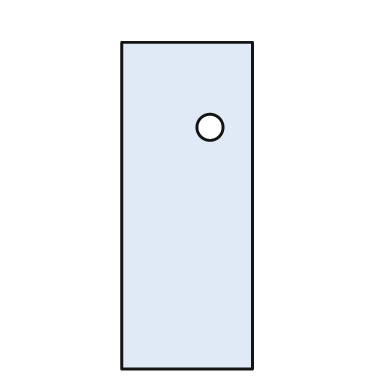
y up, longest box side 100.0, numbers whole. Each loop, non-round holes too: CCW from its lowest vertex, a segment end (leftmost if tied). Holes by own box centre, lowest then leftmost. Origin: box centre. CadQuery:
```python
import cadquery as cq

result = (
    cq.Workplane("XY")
    .moveTo(-20.0, -50.0)
    .lineTo(20.0, -50.0)
    .lineTo(20.0, 50.0)
    .lineTo(-20.0, 50.0)
    .close()
    .moveTo(7.0, 24.0)
    .circle(4.0)
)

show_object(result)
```